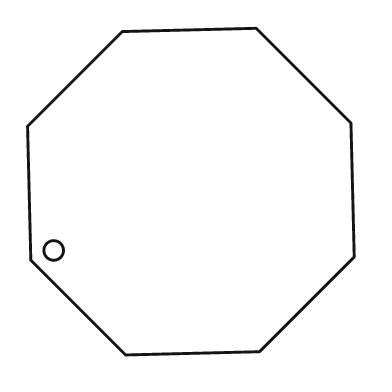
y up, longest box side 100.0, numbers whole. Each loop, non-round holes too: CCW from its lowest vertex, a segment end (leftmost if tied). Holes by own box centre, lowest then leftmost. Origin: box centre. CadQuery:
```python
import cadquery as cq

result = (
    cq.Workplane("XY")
    .moveTo(-20.0, -50.0)
    .lineTo(21.0, -49.0)
    .lineTo(50.0, -20.0)
    .lineTo(49.0, 21.0)
    .lineTo(20.0, 50.0)
    .lineTo(-21.0, 49.0)
    .lineTo(-50.0, 20.0)
    .lineTo(-49.0, -21.0)
    .close()
    .moveTo(-42.0, -18.0)
    .circle(3.0)
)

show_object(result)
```